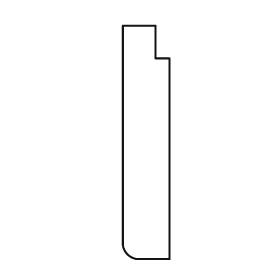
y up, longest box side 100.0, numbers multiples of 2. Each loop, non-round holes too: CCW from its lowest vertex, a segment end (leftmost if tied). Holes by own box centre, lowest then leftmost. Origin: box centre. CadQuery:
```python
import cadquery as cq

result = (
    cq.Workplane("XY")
    .moveTo(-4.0, -50.0)
    .lineTo(10.0, -50.0)
    .lineTo(10.0, 36.0)
    .lineTo(4.0, 36.0)
    .lineTo(4.0, 50.0)
    .lineTo(-10.0, 50.0)
    .lineTo(-10.0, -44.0)
    .threePointArc((-8.0, -48.0), (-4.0, -50.0))
    .close()
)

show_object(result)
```